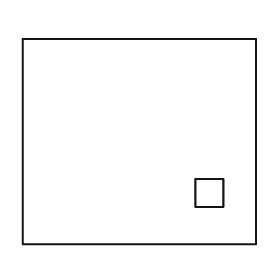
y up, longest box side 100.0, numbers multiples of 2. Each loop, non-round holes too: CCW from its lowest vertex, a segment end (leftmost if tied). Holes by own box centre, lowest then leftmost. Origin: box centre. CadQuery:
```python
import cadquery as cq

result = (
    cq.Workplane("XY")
    .moveTo(-50.0, -44.0)
    .lineTo(50.0, -44.0)
    .lineTo(50.0, 44.0)
    .lineTo(-50.0, 44.0)
    .close()
    .moveTo(24.0, -28.0)
    .lineTo(36.0, -28.0)
    .lineTo(36.0, -16.0)
    .lineTo(24.0, -16.0)
    .close()
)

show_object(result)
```